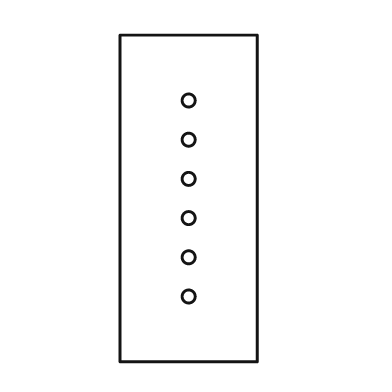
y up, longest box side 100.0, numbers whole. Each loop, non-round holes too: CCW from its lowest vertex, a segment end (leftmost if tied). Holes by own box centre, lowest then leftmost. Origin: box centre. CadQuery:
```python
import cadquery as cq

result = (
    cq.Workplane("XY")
    .moveTo(-21.0, -50.0)
    .lineTo(21.0, -50.0)
    .lineTo(21.0, 50.0)
    .lineTo(-21.0, 50.0)
    .close()
    .moveTo(0.0, -30.0)
    .circle(2.0)
    .moveTo(0.0, -18.0)
    .circle(2.0)
    .moveTo(0.0, -6.0)
    .circle(2.0)
    .moveTo(0.0, 6.0)
    .circle(2.0)
    .moveTo(0.0, 18.0)
    .circle(2.0)
    .moveTo(0.0, 30.0)
    .circle(2.0)
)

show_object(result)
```